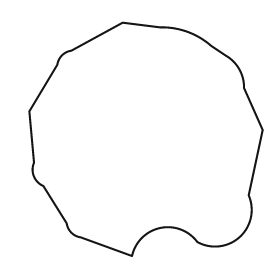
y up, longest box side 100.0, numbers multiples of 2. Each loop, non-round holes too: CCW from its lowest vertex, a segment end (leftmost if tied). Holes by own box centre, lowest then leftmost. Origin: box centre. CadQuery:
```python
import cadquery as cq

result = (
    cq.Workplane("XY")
    .moveTo(-6.0, -50.0)
    .threePointArc((6.0, -38.0), (22.0, -44.0))
    .threePointArc((40.0, -42.0), (44.0, -24.0))
    .lineTo(50.0, 4.0)
    .lineTo(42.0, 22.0)
    .threePointArc((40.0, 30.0), (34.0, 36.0))
    .lineTo(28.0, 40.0)
    .threePointArc((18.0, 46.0), (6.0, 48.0))
    .lineTo(-10.0, 50.0)
    .lineTo(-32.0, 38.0)
    .threePointArc((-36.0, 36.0), (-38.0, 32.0))
    .lineTo(-50.0, 12.0)
    .lineTo(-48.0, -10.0)
    .threePointArc((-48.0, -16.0), (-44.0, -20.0))
    .lineTo(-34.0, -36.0)
    .threePointArc((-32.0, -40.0), (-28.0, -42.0))
    .close()
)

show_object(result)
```